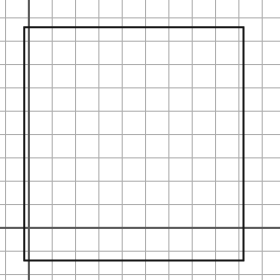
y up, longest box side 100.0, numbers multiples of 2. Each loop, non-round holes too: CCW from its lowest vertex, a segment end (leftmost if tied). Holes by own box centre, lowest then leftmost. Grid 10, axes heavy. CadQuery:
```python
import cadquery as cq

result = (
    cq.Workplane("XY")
    .moveTo(-2.0, -14.0)
    .lineTo(92.0, -14.0)
    .lineTo(92.0, 86.0)
    .lineTo(-2.0, 86.0)
    .close()
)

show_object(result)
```